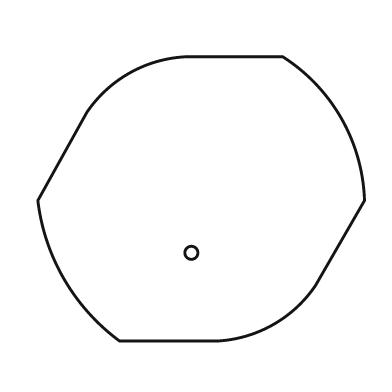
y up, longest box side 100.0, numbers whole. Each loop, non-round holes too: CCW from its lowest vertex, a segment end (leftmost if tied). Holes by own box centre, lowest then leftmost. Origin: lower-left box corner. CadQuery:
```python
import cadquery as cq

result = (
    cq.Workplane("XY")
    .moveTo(25.0, 0.0)
    .lineTo(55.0, 0.0)
    .threePointArc((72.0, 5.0), (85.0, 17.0))
    .lineTo(100.0, 43.0)
    .threePointArc((93.0, 68.0), (75.0, 87.0))
    .lineTo(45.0, 87.0)
    .threePointArc((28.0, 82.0), (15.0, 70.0))
    .lineTo(0.0, 43.0)
    .threePointArc((8.0, 19.0), (25.0, 0.0))
    .close()
    .moveTo(47.0, 27.0)
    .circle(2.0)
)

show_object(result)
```